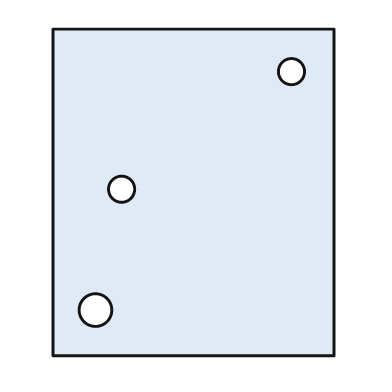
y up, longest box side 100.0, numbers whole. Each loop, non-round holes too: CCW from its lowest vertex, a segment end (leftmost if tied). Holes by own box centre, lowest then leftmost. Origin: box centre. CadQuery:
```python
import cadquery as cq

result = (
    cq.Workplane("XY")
    .moveTo(-43.0, -50.0)
    .lineTo(43.0, -50.0)
    .lineTo(43.0, 50.0)
    .lineTo(-43.0, 50.0)
    .close()
    .moveTo(-30.0, -36.0)
    .circle(5.0)
    .moveTo(-22.0, 1.0)
    .circle(4.0)
    .moveTo(30.0, 37.0)
    .circle(4.0)
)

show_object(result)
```